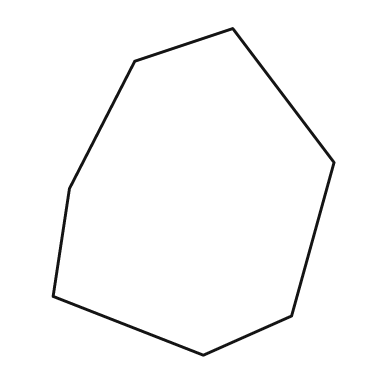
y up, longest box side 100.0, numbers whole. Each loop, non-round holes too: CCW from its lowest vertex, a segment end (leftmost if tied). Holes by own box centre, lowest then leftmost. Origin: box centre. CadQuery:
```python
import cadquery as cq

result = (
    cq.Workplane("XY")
    .moveTo(3.0, -50.0)
    .lineTo(30.0, -38.0)
    .lineTo(43.0, 9.0)
    .lineTo(12.0, 50.0)
    .lineTo(-18.0, 40.0)
    .lineTo(-38.0, 1.0)
    .lineTo(-43.0, -32.0)
    .close()
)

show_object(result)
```